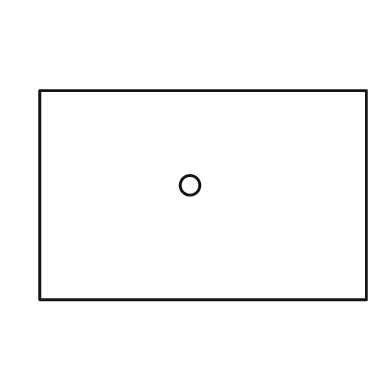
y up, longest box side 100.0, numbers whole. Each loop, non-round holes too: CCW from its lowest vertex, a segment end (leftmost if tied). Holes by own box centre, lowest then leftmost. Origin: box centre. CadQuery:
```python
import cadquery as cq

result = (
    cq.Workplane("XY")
    .moveTo(-50.0, -32.0)
    .lineTo(50.0, -32.0)
    .lineTo(50.0, 32.0)
    .lineTo(-50.0, 32.0)
    .close()
    .moveTo(-4.0, 3.0)
    .circle(3.0)
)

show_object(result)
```